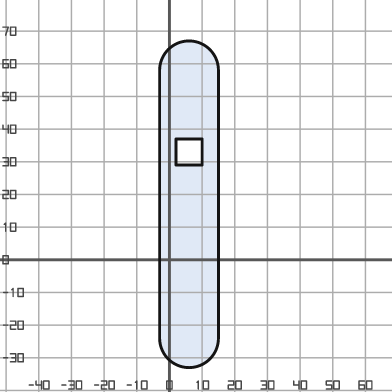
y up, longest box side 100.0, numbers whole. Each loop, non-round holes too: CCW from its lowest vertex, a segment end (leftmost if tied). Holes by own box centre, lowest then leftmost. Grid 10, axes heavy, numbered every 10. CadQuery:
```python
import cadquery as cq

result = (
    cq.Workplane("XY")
    .moveTo(-3.0, -24.0)
    .threePointArc((6.0, -33.0), (15.0, -24.0))
    .lineTo(15.0, 58.0)
    .threePointArc((6.0, 67.0), (-3.0, 58.0))
    .close()
    .moveTo(2.0, 29.0)
    .lineTo(10.0, 29.0)
    .lineTo(10.0, 37.0)
    .lineTo(2.0, 37.0)
    .close()
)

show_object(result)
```